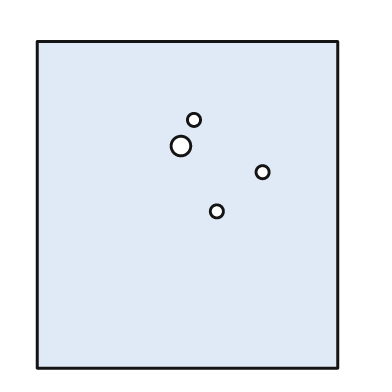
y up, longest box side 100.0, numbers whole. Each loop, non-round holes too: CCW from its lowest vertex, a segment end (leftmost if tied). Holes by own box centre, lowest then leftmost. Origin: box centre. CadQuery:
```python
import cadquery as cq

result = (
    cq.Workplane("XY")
    .moveTo(-46.0, -50.0)
    .lineTo(46.0, -50.0)
    .lineTo(46.0, 50.0)
    .lineTo(-46.0, 50.0)
    .close()
    .moveTo(9.0, -2.0)
    .circle(2.0)
    .moveTo(23.0, 10.0)
    .circle(2.0)
    .moveTo(-2.0, 18.0)
    .circle(3.0)
    .moveTo(2.0, 26.0)
    .circle(2.0)
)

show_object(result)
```